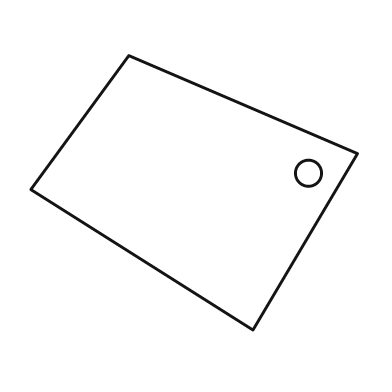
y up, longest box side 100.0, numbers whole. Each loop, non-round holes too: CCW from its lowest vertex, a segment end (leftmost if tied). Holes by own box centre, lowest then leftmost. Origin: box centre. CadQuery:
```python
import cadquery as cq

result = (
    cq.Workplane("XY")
    .moveTo(18.0, -42.0)
    .lineTo(50.0, 12.0)
    .lineTo(-20.0, 42.0)
    .lineTo(-50.0, 1.0)
    .close()
    .moveTo(35.0, 6.0)
    .circle(4.0)
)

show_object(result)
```